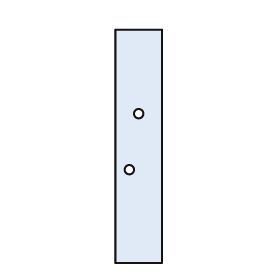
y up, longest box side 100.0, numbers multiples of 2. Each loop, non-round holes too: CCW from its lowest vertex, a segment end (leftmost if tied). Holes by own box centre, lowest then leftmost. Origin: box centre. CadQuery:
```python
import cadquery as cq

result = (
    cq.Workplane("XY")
    .moveTo(-10.0, -50.0)
    .lineTo(10.0, -50.0)
    .lineTo(10.0, 50.0)
    .lineTo(-10.0, 50.0)
    .close()
    .moveTo(-4.0, -10.0)
    .circle(2.0)
    .moveTo(0.0, 14.0)
    .circle(2.0)
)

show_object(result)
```